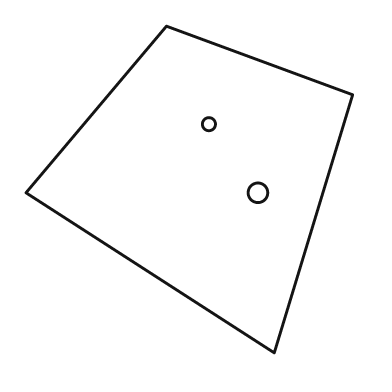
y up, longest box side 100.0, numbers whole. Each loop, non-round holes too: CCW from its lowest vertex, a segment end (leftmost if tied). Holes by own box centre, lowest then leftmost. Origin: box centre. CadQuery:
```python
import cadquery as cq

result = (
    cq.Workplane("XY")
    .moveTo(26.0, -50.0)
    .lineTo(50.0, 29.0)
    .lineTo(-7.0, 50.0)
    .lineTo(-50.0, -1.0)
    .close()
    .moveTo(21.0, -1.0)
    .circle(3.0)
    .moveTo(6.0, 20.0)
    .circle(2.0)
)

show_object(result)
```